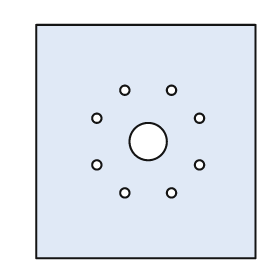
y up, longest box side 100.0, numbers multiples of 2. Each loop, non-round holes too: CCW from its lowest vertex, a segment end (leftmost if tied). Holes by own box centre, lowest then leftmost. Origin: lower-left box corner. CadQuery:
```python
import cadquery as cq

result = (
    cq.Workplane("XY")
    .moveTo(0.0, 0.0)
    .lineTo(94.0, 0.0)
    .lineTo(94.0, 100.0)
    .lineTo(0.0, 100.0)
    .close()
    .moveTo(38.0, 28.0)
    .circle(2.0)
    .moveTo(58.0, 28.0)
    .circle(2.0)
    .moveTo(26.0, 40.0)
    .circle(2.0)
    .moveTo(70.0, 40.0)
    .circle(2.0)
    .moveTo(48.0, 50.0)
    .circle(8.0)
    .moveTo(26.0, 60.0)
    .circle(2.0)
    .moveTo(70.0, 60.0)
    .circle(2.0)
    .moveTo(38.0, 72.0)
    .circle(2.0)
    .moveTo(58.0, 72.0)
    .circle(2.0)
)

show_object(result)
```